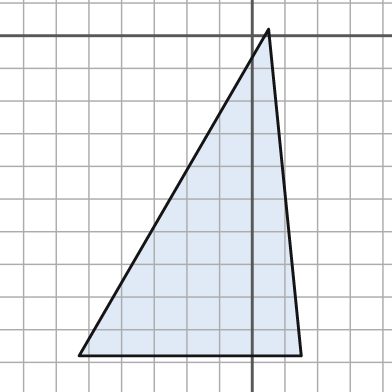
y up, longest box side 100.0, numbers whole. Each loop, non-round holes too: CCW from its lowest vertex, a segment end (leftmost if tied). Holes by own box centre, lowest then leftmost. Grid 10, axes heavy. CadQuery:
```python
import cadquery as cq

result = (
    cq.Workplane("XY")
    .moveTo(-53.0, -98.0)
    .lineTo(15.0, -98.0)
    .lineTo(5.0, 2.0)
    .close()
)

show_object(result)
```